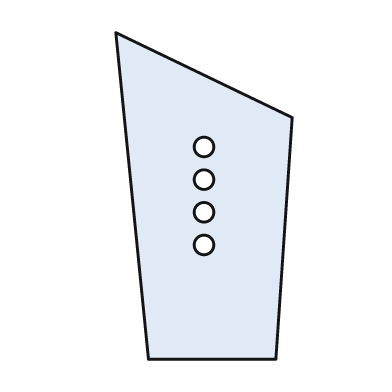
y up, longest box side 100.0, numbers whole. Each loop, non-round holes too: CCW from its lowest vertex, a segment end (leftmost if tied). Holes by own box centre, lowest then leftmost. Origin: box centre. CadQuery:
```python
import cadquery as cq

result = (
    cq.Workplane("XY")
    .moveTo(-17.0, -50.0)
    .lineTo(22.0, -50.0)
    .lineTo(27.0, 24.0)
    .lineTo(-27.0, 50.0)
    .close()
    .moveTo(0.0, -15.0)
    .circle(3.0)
    .moveTo(0.0, -5.0)
    .circle(3.0)
    .moveTo(0.0, 5.0)
    .circle(3.0)
    .moveTo(0.0, 15.0)
    .circle(3.0)
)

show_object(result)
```